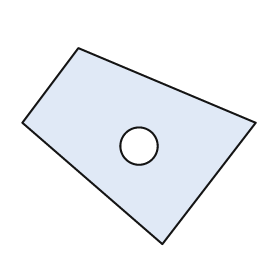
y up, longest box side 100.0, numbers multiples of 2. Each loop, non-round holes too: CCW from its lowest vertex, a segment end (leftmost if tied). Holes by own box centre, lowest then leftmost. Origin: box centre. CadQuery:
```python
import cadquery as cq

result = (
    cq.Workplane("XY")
    .moveTo(10.0, -42.0)
    .lineTo(50.0, 10.0)
    .lineTo(-26.0, 42.0)
    .lineTo(-50.0, 10.0)
    .close()
    .moveTo(0.0, 0.0)
    .circle(8.0)
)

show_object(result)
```